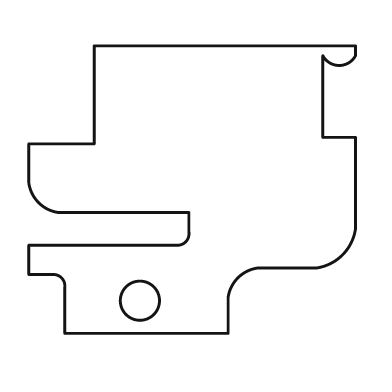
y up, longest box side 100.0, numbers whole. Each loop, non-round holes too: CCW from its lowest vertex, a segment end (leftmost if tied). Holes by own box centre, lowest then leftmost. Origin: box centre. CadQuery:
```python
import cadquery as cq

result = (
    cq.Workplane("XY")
    .moveTo(-39.0, -44.0)
    .lineTo(11.0, -44.0)
    .lineTo(11.0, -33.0)
    .threePointArc((14.0, -27.0), (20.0, -24.0))
    .lineTo(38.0, -24.0)
    .threePointArc((46.0, -20.0), (50.0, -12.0))
    .lineTo(50.0, 16.0)
    .lineTo(40.0, 16.0)
    .lineTo(40.0, 41.0)
    .threePointArc((45.0, 38.0), (50.0, 41.0))
    .lineTo(50.0, 44.0)
    .lineTo(-30.0, 44.0)
    .lineTo(-30.0, 14.0)
    .lineTo(-50.0, 14.0)
    .lineTo(-50.0, 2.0)
    .threePointArc((-47.0, -4.0), (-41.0, -7.0))
    .lineTo(-1.0, -7.0)
    .lineTo(-1.0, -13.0)
    .threePointArc((-2.0, -16.0), (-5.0, -17.0))
    .lineTo(-50.0, -17.0)
    .lineTo(-50.0, -26.0)
    .lineTo(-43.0, -26.0)
    .threePointArc((-40.0, -27.0), (-39.0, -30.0))
    .close()
    .moveTo(-16.0, -34.0)
    .circle(6.0)
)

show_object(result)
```